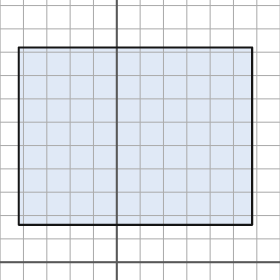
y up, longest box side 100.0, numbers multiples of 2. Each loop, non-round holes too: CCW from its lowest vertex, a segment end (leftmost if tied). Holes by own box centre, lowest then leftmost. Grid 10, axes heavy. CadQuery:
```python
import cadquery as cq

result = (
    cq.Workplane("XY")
    .moveTo(-42.0, 16.0)
    .lineTo(58.0, 16.0)
    .lineTo(58.0, 92.0)
    .lineTo(-42.0, 92.0)
    .close()
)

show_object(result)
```